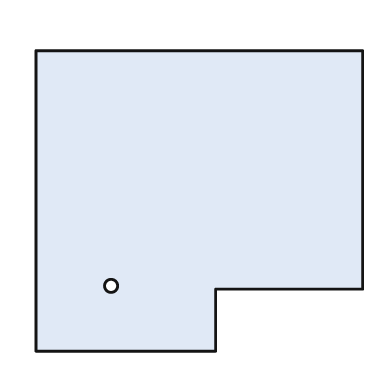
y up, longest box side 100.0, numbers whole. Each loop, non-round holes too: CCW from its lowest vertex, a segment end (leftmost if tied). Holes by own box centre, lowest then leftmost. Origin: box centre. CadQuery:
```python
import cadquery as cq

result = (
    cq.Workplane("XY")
    .moveTo(-50.0, -46.0)
    .lineTo(5.0, -46.0)
    .lineTo(5.0, -27.0)
    .lineTo(50.0, -27.0)
    .lineTo(50.0, 46.0)
    .lineTo(-50.0, 46.0)
    .close()
    .moveTo(-27.0, -26.0)
    .circle(2.0)
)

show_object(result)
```